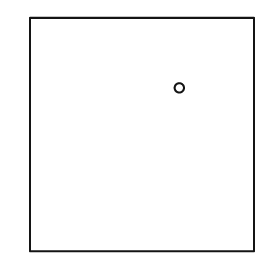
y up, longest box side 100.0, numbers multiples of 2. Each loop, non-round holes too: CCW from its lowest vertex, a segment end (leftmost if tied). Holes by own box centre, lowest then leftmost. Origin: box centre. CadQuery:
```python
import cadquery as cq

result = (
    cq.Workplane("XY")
    .moveTo(-48.0, -50.0)
    .lineTo(48.0, -50.0)
    .lineTo(48.0, 50.0)
    .lineTo(-48.0, 50.0)
    .close()
    .moveTo(16.0, 20.0)
    .circle(2.0)
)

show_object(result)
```